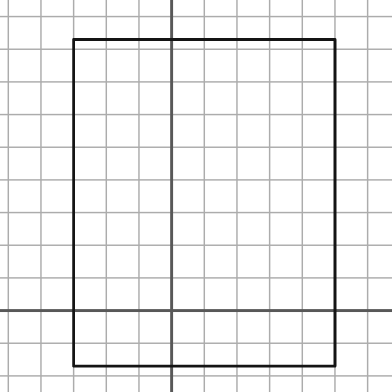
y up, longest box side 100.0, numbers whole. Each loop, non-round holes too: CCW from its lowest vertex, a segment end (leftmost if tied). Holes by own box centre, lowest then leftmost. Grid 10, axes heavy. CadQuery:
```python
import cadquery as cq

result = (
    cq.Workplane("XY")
    .moveTo(-30.0, -17.0)
    .lineTo(50.0, -17.0)
    .lineTo(50.0, 83.0)
    .lineTo(-30.0, 83.0)
    .close()
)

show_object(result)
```